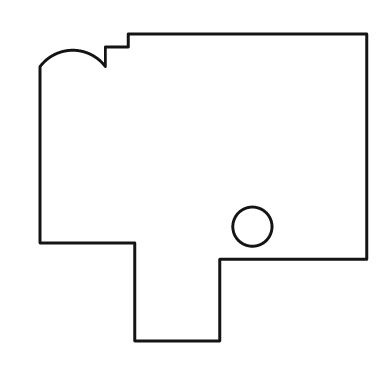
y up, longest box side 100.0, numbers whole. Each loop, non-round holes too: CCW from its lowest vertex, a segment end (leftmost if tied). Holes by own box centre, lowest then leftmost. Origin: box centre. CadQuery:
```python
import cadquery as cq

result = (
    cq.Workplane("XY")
    .moveTo(-21.0, -47.0)
    .lineTo(5.0, -47.0)
    .lineTo(5.0, -22.0)
    .lineTo(50.0, -22.0)
    .lineTo(50.0, 47.0)
    .lineTo(-23.0, 47.0)
    .lineTo(-23.0, 43.0)
    .lineTo(-30.0, 43.0)
    .lineTo(-30.0, 37.0)
    .threePointArc((-40.0, 42.0), (-50.0, 37.0))
    .lineTo(-50.0, -17.0)
    .lineTo(-21.0, -17.0)
    .close()
    .moveTo(15.0, -12.0)
    .circle(6.0)
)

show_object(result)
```